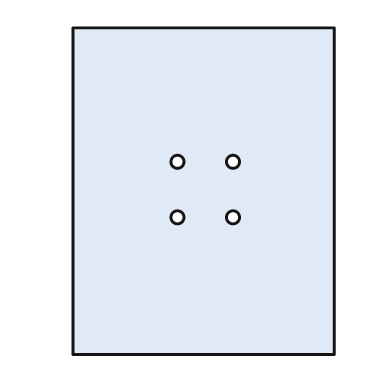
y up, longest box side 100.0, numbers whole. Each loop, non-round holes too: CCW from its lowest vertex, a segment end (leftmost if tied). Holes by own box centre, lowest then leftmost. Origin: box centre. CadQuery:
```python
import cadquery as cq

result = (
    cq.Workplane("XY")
    .moveTo(-40.0, -50.0)
    .lineTo(40.0, -50.0)
    .lineTo(40.0, 50.0)
    .lineTo(-40.0, 50.0)
    .close()
    .moveTo(-8.0, -8.0)
    .circle(2.0)
    .moveTo(9.0, -8.0)
    .circle(2.0)
    .moveTo(-8.0, 9.0)
    .circle(2.0)
    .moveTo(9.0, 9.0)
    .circle(2.0)
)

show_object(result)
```